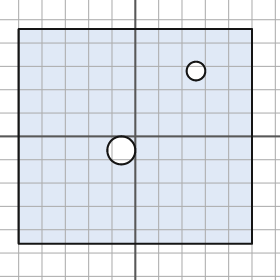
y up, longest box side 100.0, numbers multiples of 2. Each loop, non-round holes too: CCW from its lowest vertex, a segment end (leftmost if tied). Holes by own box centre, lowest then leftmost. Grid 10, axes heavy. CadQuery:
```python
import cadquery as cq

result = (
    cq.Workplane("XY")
    .moveTo(-50.0, -46.0)
    .lineTo(50.0, -46.0)
    .lineTo(50.0, 46.0)
    .lineTo(-50.0, 46.0)
    .close()
    .moveTo(-6.0, -6.0)
    .circle(6.0)
    .moveTo(26.0, 28.0)
    .circle(4.0)
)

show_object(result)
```